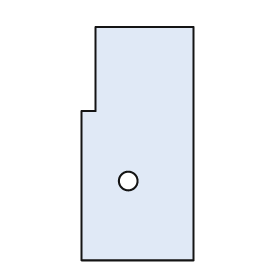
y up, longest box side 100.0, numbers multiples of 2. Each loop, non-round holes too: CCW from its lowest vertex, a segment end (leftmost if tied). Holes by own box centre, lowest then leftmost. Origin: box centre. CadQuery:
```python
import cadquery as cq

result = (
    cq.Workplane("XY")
    .moveTo(-24.0, -50.0)
    .lineTo(24.0, -50.0)
    .lineTo(24.0, 50.0)
    .lineTo(-18.0, 50.0)
    .lineTo(-18.0, 14.0)
    .lineTo(-24.0, 14.0)
    .close()
    .moveTo(-4.0, -16.0)
    .circle(4.0)
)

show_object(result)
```